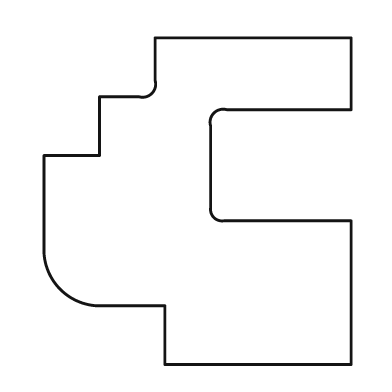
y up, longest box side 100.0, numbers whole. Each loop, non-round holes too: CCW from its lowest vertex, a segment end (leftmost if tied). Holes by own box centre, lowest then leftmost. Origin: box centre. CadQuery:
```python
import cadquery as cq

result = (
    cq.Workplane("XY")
    .moveTo(-10.0, -50.0)
    .lineTo(47.0, -50.0)
    .lineTo(47.0, -6.0)
    .lineTo(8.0, -6.0)
    .threePointArc((5.0, -5.0), (4.0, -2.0))
    .lineTo(4.0, 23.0)
    .threePointArc((5.0, 27.0), (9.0, 28.0))
    .lineTo(47.0, 28.0)
    .lineTo(47.0, 50.0)
    .lineTo(-13.0, 50.0)
    .lineTo(-13.0, 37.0)
    .threePointArc((-14.0, 33.0), (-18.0, 32.0))
    .lineTo(-30.0, 32.0)
    .lineTo(-30.0, 14.0)
    .lineTo(-47.0, 14.0)
    .lineTo(-47.0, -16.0)
    .threePointArc((-42.0, -27.0), (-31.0, -32.0))
    .lineTo(-10.0, -32.0)
    .close()
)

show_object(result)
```